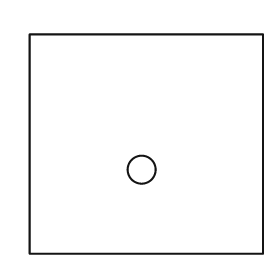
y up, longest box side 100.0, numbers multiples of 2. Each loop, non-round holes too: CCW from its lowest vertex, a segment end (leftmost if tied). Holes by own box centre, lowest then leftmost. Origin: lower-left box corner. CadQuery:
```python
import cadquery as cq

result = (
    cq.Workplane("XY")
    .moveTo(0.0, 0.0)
    .lineTo(100.0, 0.0)
    .lineTo(100.0, 94.0)
    .lineTo(0.0, 94.0)
    .close()
    .moveTo(48.0, 36.0)
    .circle(6.0)
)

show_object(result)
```